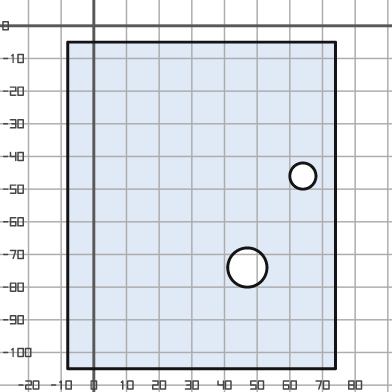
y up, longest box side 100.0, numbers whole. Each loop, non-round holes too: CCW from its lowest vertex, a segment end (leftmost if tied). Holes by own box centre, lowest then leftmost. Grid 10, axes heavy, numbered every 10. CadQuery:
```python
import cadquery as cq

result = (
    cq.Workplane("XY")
    .moveTo(-8.0, -105.0)
    .lineTo(74.0, -105.0)
    .lineTo(74.0, -5.0)
    .lineTo(-8.0, -5.0)
    .close()
    .moveTo(47.0, -74.0)
    .circle(6.0)
    .moveTo(64.0, -46.0)
    .circle(4.0)
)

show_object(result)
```